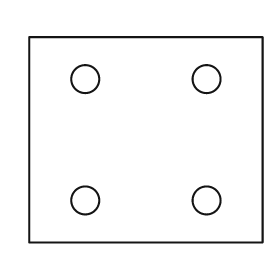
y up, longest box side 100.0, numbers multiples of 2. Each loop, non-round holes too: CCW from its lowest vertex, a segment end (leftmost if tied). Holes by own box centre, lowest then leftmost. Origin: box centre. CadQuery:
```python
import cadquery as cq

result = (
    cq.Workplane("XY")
    .moveTo(-50.0, -44.0)
    .lineTo(50.0, -44.0)
    .lineTo(50.0, 44.0)
    .lineTo(-50.0, 44.0)
    .close()
    .moveTo(-26.0, -26.0)
    .circle(6.0)
    .moveTo(26.0, -26.0)
    .circle(6.0)
    .moveTo(-26.0, 26.0)
    .circle(6.0)
    .moveTo(26.0, 26.0)
    .circle(6.0)
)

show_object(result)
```